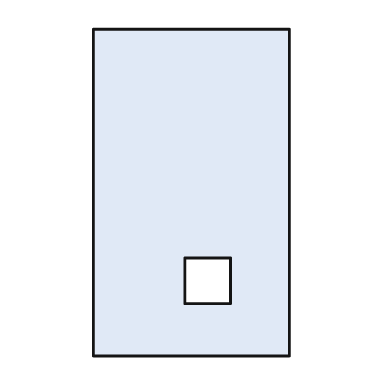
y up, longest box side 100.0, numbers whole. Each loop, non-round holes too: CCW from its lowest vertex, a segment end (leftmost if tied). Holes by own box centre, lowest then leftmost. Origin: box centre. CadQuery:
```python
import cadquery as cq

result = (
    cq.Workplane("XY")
    .moveTo(-30.0, -50.0)
    .lineTo(30.0, -50.0)
    .lineTo(30.0, 50.0)
    .lineTo(-30.0, 50.0)
    .close()
    .moveTo(-2.0, -34.0)
    .lineTo(12.0, -34.0)
    .lineTo(12.0, -20.0)
    .lineTo(-2.0, -20.0)
    .close()
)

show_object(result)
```